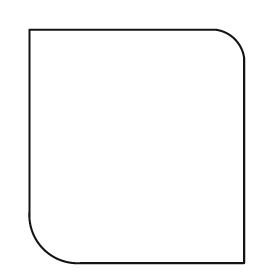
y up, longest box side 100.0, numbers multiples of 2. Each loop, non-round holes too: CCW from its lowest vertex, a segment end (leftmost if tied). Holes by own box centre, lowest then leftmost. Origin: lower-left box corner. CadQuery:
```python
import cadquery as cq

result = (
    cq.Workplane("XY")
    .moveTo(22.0, 0.0)
    .lineTo(92.0, 0.0)
    .lineTo(92.0, 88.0)
    .threePointArc((88.0, 96.0), (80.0, 100.0))
    .lineTo(0.0, 100.0)
    .lineTo(0.0, 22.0)
    .threePointArc((6.0, 6.0), (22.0, 0.0))
    .close()
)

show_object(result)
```